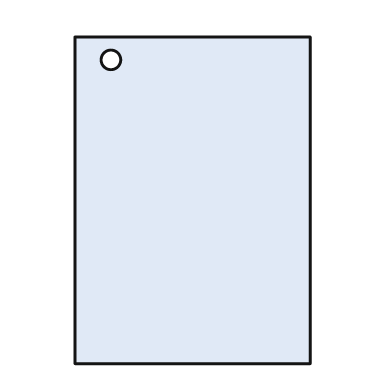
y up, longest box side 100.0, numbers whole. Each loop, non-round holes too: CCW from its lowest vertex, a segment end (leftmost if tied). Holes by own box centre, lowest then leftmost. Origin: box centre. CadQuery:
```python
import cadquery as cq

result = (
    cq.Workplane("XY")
    .moveTo(-36.0, -50.0)
    .lineTo(36.0, -50.0)
    .lineTo(36.0, 50.0)
    .lineTo(-36.0, 50.0)
    .close()
    .moveTo(-25.0, 43.0)
    .circle(3.0)
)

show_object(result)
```